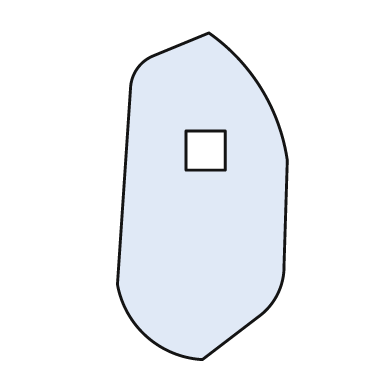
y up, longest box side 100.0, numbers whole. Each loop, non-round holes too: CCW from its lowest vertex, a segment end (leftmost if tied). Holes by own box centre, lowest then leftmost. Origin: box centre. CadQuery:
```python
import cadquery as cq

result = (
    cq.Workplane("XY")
    .moveTo(0.0, -50.0)
    .lineTo(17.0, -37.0)
    .threePointArc((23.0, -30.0), (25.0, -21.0))
    .lineTo(26.0, 11.0)
    .threePointArc((18.0, 33.0), (2.0, 50.0))
    .lineTo(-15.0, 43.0)
    .threePointArc((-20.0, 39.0), (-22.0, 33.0))
    .lineTo(-26.0, -27.0)
    .threePointArc((-17.0, -43.0), (0.0, -50.0))
    .close()
    .moveTo(-5.0, 8.0)
    .lineTo(7.0, 8.0)
    .lineTo(7.0, 20.0)
    .lineTo(-5.0, 20.0)
    .close()
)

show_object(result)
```